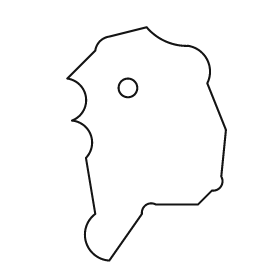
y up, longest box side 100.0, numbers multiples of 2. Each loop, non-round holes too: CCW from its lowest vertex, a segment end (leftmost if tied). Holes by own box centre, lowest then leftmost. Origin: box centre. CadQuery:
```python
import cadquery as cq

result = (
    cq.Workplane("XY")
    .moveTo(-16.0, -50.0)
    .lineTo(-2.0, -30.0)
    .threePointArc((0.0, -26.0), (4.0, -26.0))
    .lineTo(22.0, -26.0)
    .lineTo(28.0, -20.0)
    .threePointArc((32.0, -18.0), (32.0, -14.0))
    .lineTo(34.0, 6.0)
    .lineTo(26.0, 26.0)
    .threePointArc((26.0, 36.0), (18.0, 42.0))
    .threePointArc((8.0, 44.0), (0.0, 50.0))
    .lineTo(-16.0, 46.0)
    .threePointArc((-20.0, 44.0), (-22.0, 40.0))
    .lineTo(-34.0, 28.0)
    .threePointArc((-26.0, 20.0), (-32.0, 10.0))
    .threePointArc((-24.0, 4.0), (-26.0, -6.0))
    .lineTo(-22.0, -30.0)
    .threePointArc((-26.0, -42.0), (-16.0, -50.0))
    .close()
    .moveTo(-8.0, 24.0)
    .circle(4.0)
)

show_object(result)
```